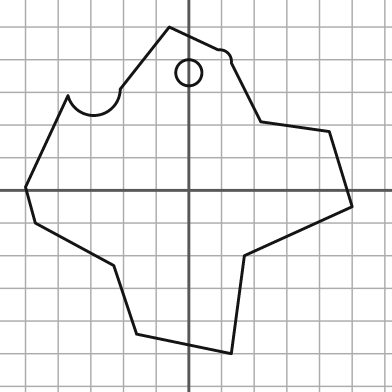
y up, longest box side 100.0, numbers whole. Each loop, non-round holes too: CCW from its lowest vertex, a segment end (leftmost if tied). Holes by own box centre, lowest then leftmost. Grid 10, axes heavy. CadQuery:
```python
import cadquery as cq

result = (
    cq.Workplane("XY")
    .moveTo(13.0, -50.0)
    .lineTo(17.0, -20.0)
    .lineTo(50.0, -5.0)
    .lineTo(43.0, 18.0)
    .lineTo(22.0, 21.0)
    .lineTo(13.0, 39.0)
    .threePointArc((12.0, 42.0), (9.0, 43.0))
    .lineTo(-6.0, 50.0)
    .lineTo(-21.0, 31.0)
    .threePointArc((-28.0, 23.0), (-37.0, 29.0))
    .lineTo(-50.0, 1.0)
    .lineTo(-47.0, -10.0)
    .lineTo(-23.0, -23.0)
    .lineTo(-16.0, -44.0)
    .close()
    .moveTo(0.0, 36.0)
    .circle(4.0)
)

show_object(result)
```